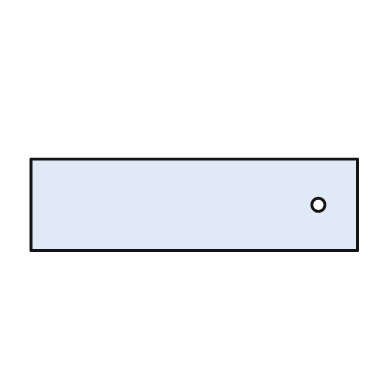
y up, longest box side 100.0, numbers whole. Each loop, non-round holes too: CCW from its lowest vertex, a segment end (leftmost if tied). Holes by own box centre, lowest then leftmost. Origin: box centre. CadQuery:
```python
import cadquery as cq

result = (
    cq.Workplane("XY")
    .moveTo(-50.0, -14.0)
    .lineTo(50.0, -14.0)
    .lineTo(50.0, 14.0)
    .lineTo(-50.0, 14.0)
    .close()
    .moveTo(38.0, 0.0)
    .circle(2.0)
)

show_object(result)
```